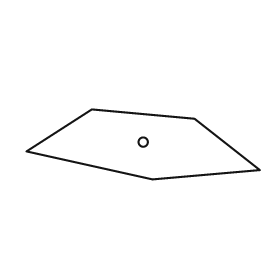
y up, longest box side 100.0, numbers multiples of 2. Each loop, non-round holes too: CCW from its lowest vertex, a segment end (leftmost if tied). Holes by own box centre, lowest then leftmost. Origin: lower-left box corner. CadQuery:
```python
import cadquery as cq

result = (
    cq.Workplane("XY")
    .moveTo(54.0, 0.0)
    .lineTo(100.0, 4.0)
    .lineTo(72.0, 26.0)
    .lineTo(28.0, 30.0)
    .lineTo(0.0, 12.0)
    .close()
    .moveTo(50.0, 16.0)
    .circle(2.0)
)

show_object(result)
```